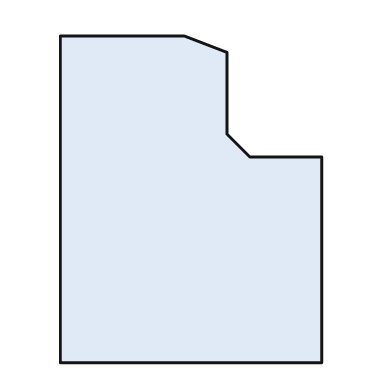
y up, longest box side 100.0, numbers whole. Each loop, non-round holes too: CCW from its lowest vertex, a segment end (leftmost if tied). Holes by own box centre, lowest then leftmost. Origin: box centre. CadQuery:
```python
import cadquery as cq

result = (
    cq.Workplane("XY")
    .moveTo(-40.0, -50.0)
    .lineTo(40.0, -50.0)
    .lineTo(40.0, 13.0)
    .lineTo(18.0, 13.0)
    .lineTo(11.0, 20.0)
    .lineTo(11.0, 45.0)
    .lineTo(-2.0, 50.0)
    .lineTo(-40.0, 50.0)
    .close()
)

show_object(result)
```